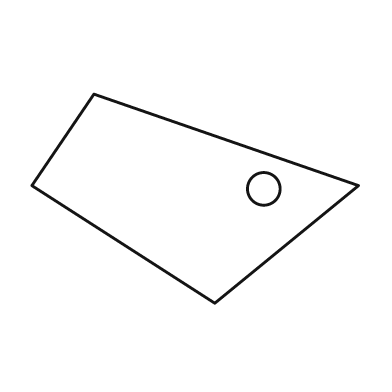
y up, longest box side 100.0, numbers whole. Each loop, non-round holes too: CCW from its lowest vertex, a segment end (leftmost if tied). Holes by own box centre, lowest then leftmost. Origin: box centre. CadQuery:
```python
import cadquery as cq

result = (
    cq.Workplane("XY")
    .moveTo(6.0, -32.0)
    .lineTo(50.0, 4.0)
    .lineTo(-31.0, 32.0)
    .lineTo(-50.0, 4.0)
    .close()
    .moveTo(21.0, 3.0)
    .circle(5.0)
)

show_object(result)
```